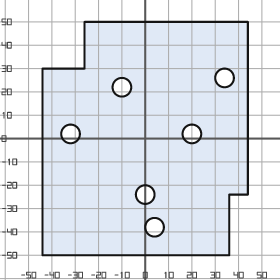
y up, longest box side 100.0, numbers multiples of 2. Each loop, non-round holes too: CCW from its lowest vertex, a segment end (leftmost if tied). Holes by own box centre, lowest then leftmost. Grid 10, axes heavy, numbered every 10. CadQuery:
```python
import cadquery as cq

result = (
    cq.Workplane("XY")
    .moveTo(-44.0, -50.0)
    .lineTo(36.0, -50.0)
    .lineTo(36.0, -24.0)
    .lineTo(44.0, -24.0)
    .lineTo(44.0, 50.0)
    .lineTo(-26.0, 50.0)
    .lineTo(-26.0, 30.0)
    .lineTo(-44.0, 30.0)
    .close()
    .moveTo(4.0, -38.0)
    .circle(4.0)
    .moveTo(0.0, -24.0)
    .circle(4.0)
    .moveTo(-32.0, 2.0)
    .circle(4.0)
    .moveTo(20.0, 2.0)
    .circle(4.0)
    .moveTo(-10.0, 22.0)
    .circle(4.0)
    .moveTo(34.0, 26.0)
    .circle(4.0)
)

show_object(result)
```